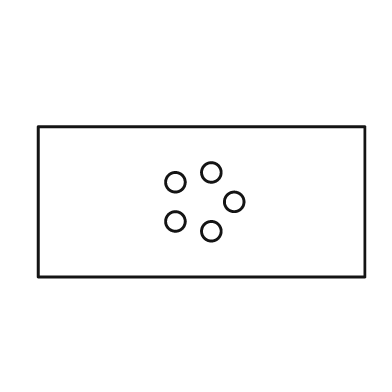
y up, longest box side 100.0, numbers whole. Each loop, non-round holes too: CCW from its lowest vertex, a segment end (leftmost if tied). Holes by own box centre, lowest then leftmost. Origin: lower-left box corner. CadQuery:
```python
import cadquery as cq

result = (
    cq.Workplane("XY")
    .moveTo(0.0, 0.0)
    .lineTo(100.0, 0.0)
    .lineTo(100.0, 46.0)
    .lineTo(0.0, 46.0)
    .close()
    .moveTo(53.0, 14.0)
    .circle(3.0)
    .moveTo(42.0, 17.0)
    .circle(3.0)
    .moveTo(60.0, 23.0)
    .circle(3.0)
    .moveTo(42.0, 29.0)
    .circle(3.0)
    .moveTo(53.0, 32.0)
    .circle(3.0)
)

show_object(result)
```